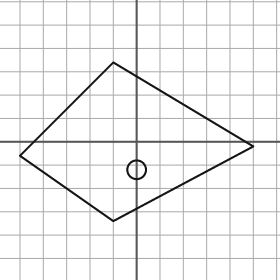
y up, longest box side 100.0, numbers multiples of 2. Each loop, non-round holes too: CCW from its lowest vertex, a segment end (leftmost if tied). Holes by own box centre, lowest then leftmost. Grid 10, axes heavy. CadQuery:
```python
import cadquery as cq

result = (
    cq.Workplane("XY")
    .moveTo(-10.0, -34.0)
    .lineTo(50.0, -2.0)
    .lineTo(-10.0, 34.0)
    .lineTo(-50.0, -6.0)
    .close()
    .moveTo(0.0, -12.0)
    .circle(4.0)
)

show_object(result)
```